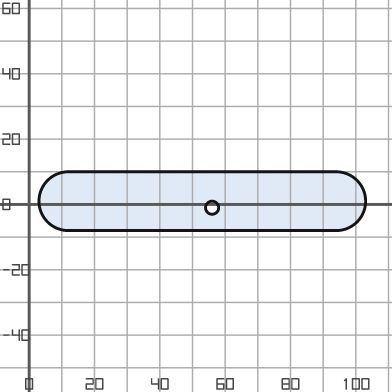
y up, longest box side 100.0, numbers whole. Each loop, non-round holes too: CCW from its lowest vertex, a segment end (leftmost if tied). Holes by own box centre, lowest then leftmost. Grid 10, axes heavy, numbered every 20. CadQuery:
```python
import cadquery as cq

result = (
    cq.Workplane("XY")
    .moveTo(12.0, -8.0)
    .lineTo(94.0, -8.0)
    .threePointArc((103.0, 1.0), (94.0, 10.0))
    .lineTo(12.0, 10.0)
    .threePointArc((3.0, 1.0), (12.0, -8.0))
    .close()
    .moveTo(56.0, -1.0)
    .circle(2.0)
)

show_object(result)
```